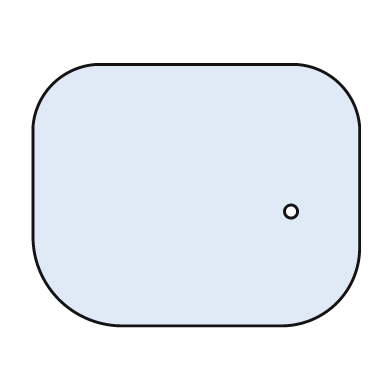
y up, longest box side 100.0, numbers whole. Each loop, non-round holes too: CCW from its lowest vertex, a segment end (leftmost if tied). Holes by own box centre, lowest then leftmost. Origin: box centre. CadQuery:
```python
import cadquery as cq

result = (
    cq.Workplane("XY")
    .moveTo(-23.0, -40.0)
    .lineTo(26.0, -40.0)
    .threePointArc((43.0, -33.0), (50.0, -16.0))
    .lineTo(50.0, 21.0)
    .threePointArc((44.0, 34.0), (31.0, 40.0))
    .lineTo(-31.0, 40.0)
    .threePointArc((-44.0, 34.0), (-50.0, 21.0))
    .lineTo(-50.0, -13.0)
    .threePointArc((-42.0, -32.0), (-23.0, -40.0))
    .close()
    .moveTo(29.0, -5.0)
    .circle(2.0)
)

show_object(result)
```